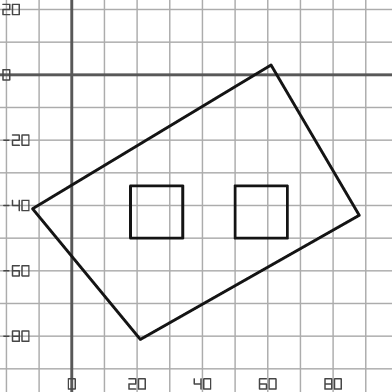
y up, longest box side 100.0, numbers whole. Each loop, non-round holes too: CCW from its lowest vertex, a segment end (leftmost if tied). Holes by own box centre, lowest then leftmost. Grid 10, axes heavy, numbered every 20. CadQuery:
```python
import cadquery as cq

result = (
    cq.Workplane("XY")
    .moveTo(21.0, -81.0)
    .lineTo(88.0, -43.0)
    .lineTo(61.0, 3.0)
    .lineTo(-12.0, -41.0)
    .close()
    .moveTo(18.0, -50.0)
    .lineTo(34.0, -50.0)
    .lineTo(34.0, -34.0)
    .lineTo(18.0, -34.0)
    .close()
    .moveTo(50.0, -50.0)
    .lineTo(66.0, -50.0)
    .lineTo(66.0, -34.0)
    .lineTo(50.0, -34.0)
    .close()
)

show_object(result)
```